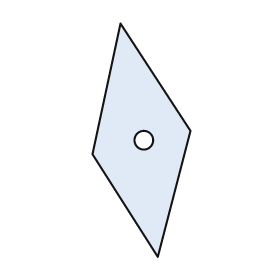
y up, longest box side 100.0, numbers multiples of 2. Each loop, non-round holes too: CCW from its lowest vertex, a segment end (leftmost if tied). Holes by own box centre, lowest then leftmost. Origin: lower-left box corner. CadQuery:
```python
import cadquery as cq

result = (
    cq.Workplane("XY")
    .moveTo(28.0, 0.0)
    .lineTo(42.0, 54.0)
    .lineTo(12.0, 100.0)
    .lineTo(0.0, 44.0)
    .close()
    .moveTo(22.0, 50.0)
    .circle(4.0)
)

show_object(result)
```